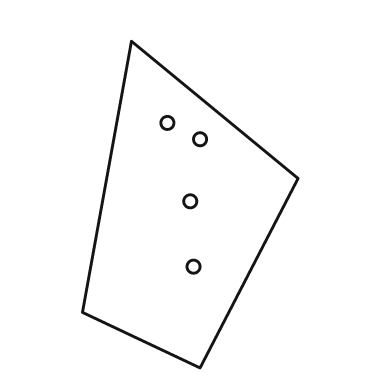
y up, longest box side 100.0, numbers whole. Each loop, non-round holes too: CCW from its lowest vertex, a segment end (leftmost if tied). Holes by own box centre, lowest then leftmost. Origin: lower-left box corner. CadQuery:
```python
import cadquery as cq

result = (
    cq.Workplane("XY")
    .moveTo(36.0, 0.0)
    .lineTo(66.0, 58.0)
    .lineTo(15.0, 100.0)
    .lineTo(0.0, 17.0)
    .close()
    .moveTo(34.0, 31.0)
    .circle(2.0)
    .moveTo(33.0, 51.0)
    .circle(2.0)
    .moveTo(36.0, 70.0)
    .circle(2.0)
    .moveTo(26.0, 75.0)
    .circle(2.0)
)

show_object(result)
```